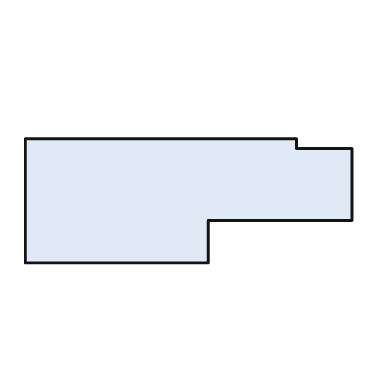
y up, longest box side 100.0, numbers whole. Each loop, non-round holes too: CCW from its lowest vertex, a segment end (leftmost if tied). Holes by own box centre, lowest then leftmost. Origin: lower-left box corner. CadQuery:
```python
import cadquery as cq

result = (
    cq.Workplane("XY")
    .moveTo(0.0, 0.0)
    .lineTo(56.0, 0.0)
    .lineTo(56.0, 13.0)
    .lineTo(100.0, 13.0)
    .lineTo(100.0, 35.0)
    .lineTo(83.0, 35.0)
    .lineTo(83.0, 38.0)
    .lineTo(0.0, 38.0)
    .close()
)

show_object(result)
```